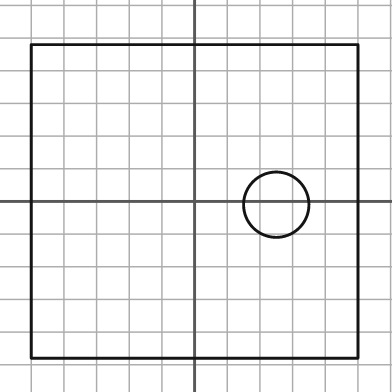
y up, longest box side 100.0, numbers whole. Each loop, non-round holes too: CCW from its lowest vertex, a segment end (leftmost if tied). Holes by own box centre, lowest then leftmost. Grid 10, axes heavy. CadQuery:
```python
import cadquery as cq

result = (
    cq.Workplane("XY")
    .moveTo(-50.0, -48.0)
    .lineTo(50.0, -48.0)
    .lineTo(50.0, 48.0)
    .lineTo(-50.0, 48.0)
    .close()
    .moveTo(25.0, -1.0)
    .circle(10.0)
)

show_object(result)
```